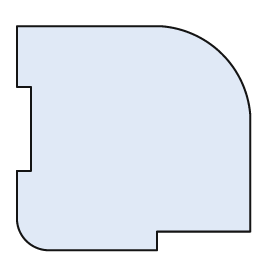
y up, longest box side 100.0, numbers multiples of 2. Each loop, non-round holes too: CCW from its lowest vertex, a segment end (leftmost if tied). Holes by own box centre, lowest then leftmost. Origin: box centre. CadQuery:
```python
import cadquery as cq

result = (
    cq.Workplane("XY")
    .moveTo(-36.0, -48.0)
    .lineTo(10.0, -48.0)
    .lineTo(10.0, -40.0)
    .lineTo(50.0, -40.0)
    .lineTo(50.0, 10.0)
    .threePointArc((38.0, 36.0), (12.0, 48.0))
    .lineTo(-50.0, 48.0)
    .lineTo(-50.0, 22.0)
    .lineTo(-44.0, 22.0)
    .lineTo(-44.0, -14.0)
    .lineTo(-50.0, -14.0)
    .lineTo(-50.0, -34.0)
    .threePointArc((-46.0, -44.0), (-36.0, -48.0))
    .close()
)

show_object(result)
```